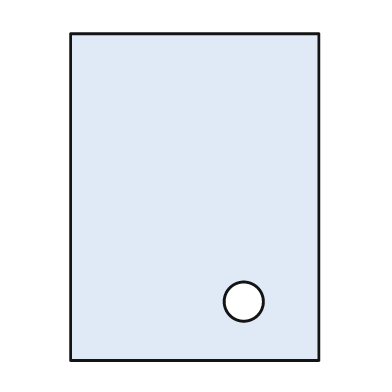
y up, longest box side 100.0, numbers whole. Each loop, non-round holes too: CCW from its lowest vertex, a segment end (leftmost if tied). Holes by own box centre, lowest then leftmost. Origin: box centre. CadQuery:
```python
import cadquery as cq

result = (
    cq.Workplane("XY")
    .moveTo(-38.0, -50.0)
    .lineTo(38.0, -50.0)
    .lineTo(38.0, 50.0)
    .lineTo(-38.0, 50.0)
    .close()
    .moveTo(15.0, -32.0)
    .circle(6.0)
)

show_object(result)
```